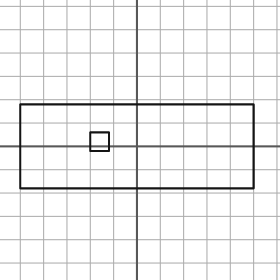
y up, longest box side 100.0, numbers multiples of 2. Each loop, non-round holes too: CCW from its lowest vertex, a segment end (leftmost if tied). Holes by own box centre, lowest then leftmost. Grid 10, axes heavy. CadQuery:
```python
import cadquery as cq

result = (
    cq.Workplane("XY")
    .moveTo(-50.0, -18.0)
    .lineTo(50.0, -18.0)
    .lineTo(50.0, 18.0)
    .lineTo(-50.0, 18.0)
    .close()
    .moveTo(-20.0, -2.0)
    .lineTo(-12.0, -2.0)
    .lineTo(-12.0, 6.0)
    .lineTo(-20.0, 6.0)
    .close()
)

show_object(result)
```